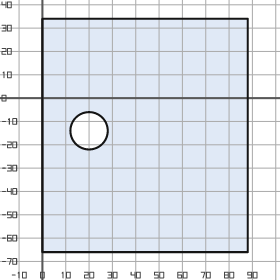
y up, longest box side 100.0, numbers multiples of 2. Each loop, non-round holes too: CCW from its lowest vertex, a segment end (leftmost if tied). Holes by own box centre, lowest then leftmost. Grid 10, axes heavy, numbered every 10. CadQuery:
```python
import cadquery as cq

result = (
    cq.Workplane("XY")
    .moveTo(0.0, -66.0)
    .lineTo(88.0, -66.0)
    .lineTo(88.0, 34.0)
    .lineTo(0.0, 34.0)
    .close()
    .moveTo(20.0, -14.0)
    .circle(8.0)
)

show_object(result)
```